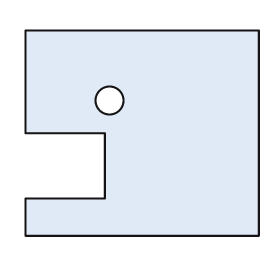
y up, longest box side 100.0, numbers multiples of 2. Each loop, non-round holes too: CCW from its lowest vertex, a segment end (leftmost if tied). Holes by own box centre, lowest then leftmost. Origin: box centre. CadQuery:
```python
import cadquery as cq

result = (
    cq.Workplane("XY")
    .moveTo(-50.0, -44.0)
    .lineTo(50.0, -44.0)
    .lineTo(50.0, 44.0)
    .lineTo(-50.0, 44.0)
    .lineTo(-50.0, 0.0)
    .lineTo(-16.0, 0.0)
    .lineTo(-16.0, -28.0)
    .lineTo(-50.0, -28.0)
    .close()
    .moveTo(-14.0, 14.0)
    .circle(6.0)
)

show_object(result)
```